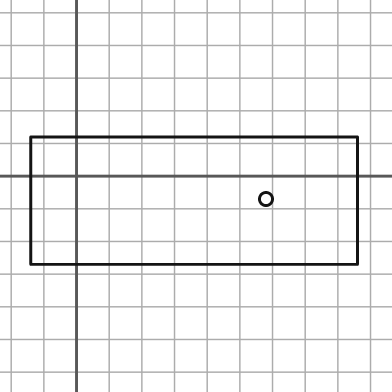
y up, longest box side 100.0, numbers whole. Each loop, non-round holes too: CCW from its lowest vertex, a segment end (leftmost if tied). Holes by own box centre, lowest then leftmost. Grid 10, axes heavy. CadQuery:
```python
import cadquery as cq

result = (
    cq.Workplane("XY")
    .moveTo(-14.0, -27.0)
    .lineTo(86.0, -27.0)
    .lineTo(86.0, 12.0)
    .lineTo(-14.0, 12.0)
    .close()
    .moveTo(58.0, -7.0)
    .circle(2.0)
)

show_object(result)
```